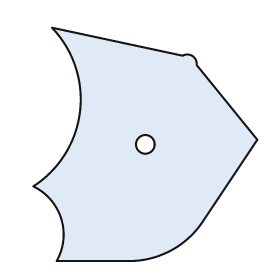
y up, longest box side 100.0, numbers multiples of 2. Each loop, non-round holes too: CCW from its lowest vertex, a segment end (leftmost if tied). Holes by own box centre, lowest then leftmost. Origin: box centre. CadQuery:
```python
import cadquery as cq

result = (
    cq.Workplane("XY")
    .moveTo(-38.0, -50.0)
    .lineTo(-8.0, -50.0)
    .threePointArc((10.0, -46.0), (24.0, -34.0))
    .lineTo(48.0, 2.0)
    .lineTo(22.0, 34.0)
    .threePointArc((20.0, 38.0), (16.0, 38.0))
    .lineTo(-40.0, 50.0)
    .threePointArc((-28.0, 14.0), (-48.0, -18.0))
    .threePointArc((-36.0, -32.0), (-38.0, -50.0))
    .close()
    .moveTo(0.0, 0.0)
    .circle(4.0)
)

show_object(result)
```